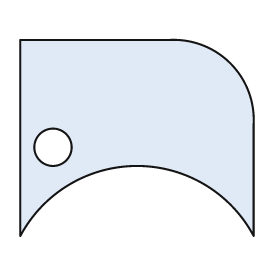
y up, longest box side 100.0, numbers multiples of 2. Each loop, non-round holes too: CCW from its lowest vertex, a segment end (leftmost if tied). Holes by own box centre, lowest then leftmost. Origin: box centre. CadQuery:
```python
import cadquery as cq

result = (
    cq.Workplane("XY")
    .moveTo(-50.0, -42.0)
    .threePointArc((0.0, -12.0), (50.0, -42.0))
    .lineTo(50.0, 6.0)
    .threePointArc((40.0, 32.0), (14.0, 42.0))
    .lineTo(-50.0, 42.0)
    .close()
    .moveTo(-36.0, -4.0)
    .circle(8.0)
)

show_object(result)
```